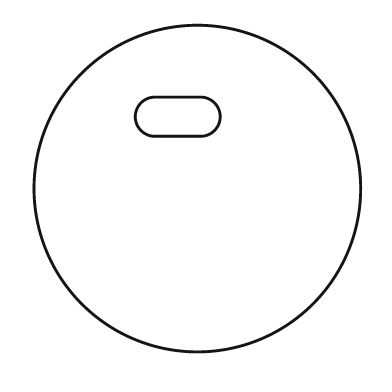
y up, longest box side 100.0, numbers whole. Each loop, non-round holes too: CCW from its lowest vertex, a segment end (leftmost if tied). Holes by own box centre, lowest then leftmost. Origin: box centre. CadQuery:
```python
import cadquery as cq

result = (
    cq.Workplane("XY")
    .moveTo(0.0, 0.0)
    .circle(50.0)
    .moveTo(-13.0, 16.0)
    .lineTo(1.0, 16.0)
    .threePointArc((7.0, 22.0), (1.0, 28.0))
    .lineTo(-13.0, 28.0)
    .threePointArc((-19.0, 22.0), (-13.0, 16.0))
    .close()
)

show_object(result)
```